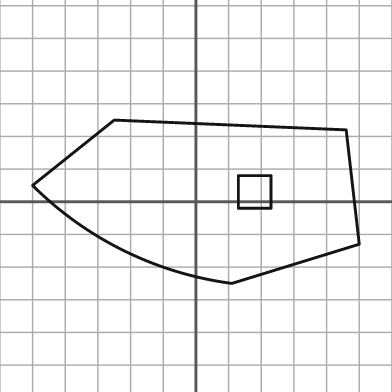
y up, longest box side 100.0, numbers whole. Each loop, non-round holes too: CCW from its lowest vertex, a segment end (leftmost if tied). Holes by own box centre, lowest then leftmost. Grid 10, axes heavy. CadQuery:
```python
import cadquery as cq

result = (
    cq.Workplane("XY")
    .moveTo(11.0, -25.0)
    .lineTo(50.0, -13.0)
    .lineTo(46.0, 22.0)
    .lineTo(-25.0, 25.0)
    .lineTo(-50.0, 5.0)
    .threePointArc((-22.0, -15.0), (11.0, -25.0))
    .close()
    .moveTo(13.0, -2.0)
    .lineTo(23.0, -2.0)
    .lineTo(23.0, 8.0)
    .lineTo(13.0, 8.0)
    .close()
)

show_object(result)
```